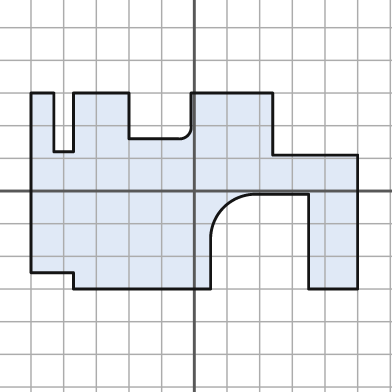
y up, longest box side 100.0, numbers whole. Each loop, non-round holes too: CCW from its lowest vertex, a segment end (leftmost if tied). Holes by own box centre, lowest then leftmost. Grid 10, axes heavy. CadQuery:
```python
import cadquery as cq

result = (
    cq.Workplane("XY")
    .moveTo(-37.0, -30.0)
    .lineTo(5.0, -30.0)
    .lineTo(5.0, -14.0)
    .threePointArc((9.0, -5.0), (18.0, -1.0))
    .lineTo(35.0, -1.0)
    .lineTo(35.0, -30.0)
    .lineTo(50.0, -30.0)
    .lineTo(50.0, 11.0)
    .lineTo(24.0, 11.0)
    .lineTo(24.0, 30.0)
    .lineTo(-1.0, 30.0)
    .lineTo(-1.0, 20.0)
    .threePointArc((-2.0, 17.0), (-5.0, 16.0))
    .lineTo(-20.0, 16.0)
    .lineTo(-20.0, 30.0)
    .lineTo(-37.0, 30.0)
    .lineTo(-37.0, 12.0)
    .lineTo(-43.0, 12.0)
    .lineTo(-43.0, 30.0)
    .lineTo(-50.0, 30.0)
    .lineTo(-50.0, -25.0)
    .lineTo(-37.0, -25.0)
    .close()
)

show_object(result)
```